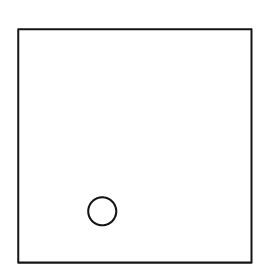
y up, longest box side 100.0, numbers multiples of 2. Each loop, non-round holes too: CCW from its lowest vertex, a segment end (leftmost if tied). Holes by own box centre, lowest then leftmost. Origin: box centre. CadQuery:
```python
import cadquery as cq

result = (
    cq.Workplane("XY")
    .moveTo(-50.0, -50.0)
    .lineTo(50.0, -50.0)
    .lineTo(50.0, 50.0)
    .lineTo(-50.0, 50.0)
    .close()
    .moveTo(-14.0, -28.0)
    .circle(6.0)
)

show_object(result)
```